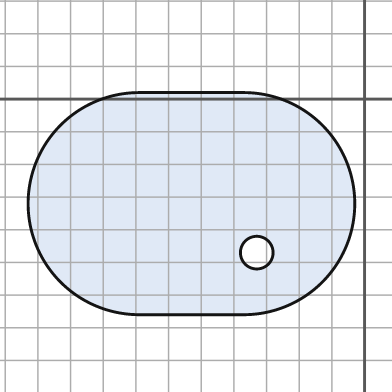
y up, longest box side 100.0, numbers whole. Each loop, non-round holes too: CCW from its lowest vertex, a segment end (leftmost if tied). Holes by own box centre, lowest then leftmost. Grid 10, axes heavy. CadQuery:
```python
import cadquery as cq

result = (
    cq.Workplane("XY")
    .moveTo(-69.0, -66.0)
    .lineTo(-37.0, -66.0)
    .threePointArc((-3.0, -32.0), (-37.0, 2.0))
    .lineTo(-69.0, 2.0)
    .threePointArc((-103.0, -32.0), (-69.0, -66.0))
    .close()
    .moveTo(-33.0, -47.0)
    .circle(5.0)
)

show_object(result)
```